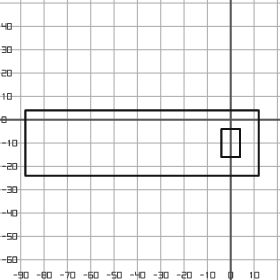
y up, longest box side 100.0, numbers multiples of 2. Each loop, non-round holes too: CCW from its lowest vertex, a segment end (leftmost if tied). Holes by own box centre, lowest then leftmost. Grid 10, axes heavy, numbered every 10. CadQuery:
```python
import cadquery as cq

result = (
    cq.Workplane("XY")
    .moveTo(-88.0, -24.0)
    .lineTo(12.0, -24.0)
    .lineTo(12.0, 4.0)
    .lineTo(-88.0, 4.0)
    .close()
    .moveTo(-4.0, -16.0)
    .lineTo(4.0, -16.0)
    .lineTo(4.0, -4.0)
    .lineTo(-4.0, -4.0)
    .close()
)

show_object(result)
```